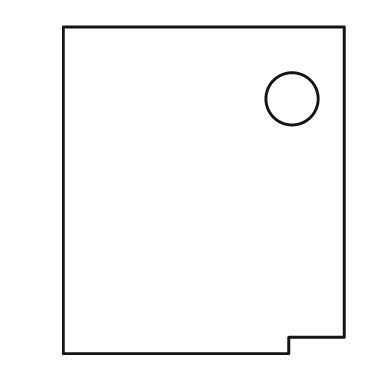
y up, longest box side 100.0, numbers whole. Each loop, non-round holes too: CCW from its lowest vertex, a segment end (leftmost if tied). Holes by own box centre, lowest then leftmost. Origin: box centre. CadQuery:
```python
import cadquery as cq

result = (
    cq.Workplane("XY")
    .moveTo(-43.0, -50.0)
    .lineTo(26.0, -50.0)
    .lineTo(26.0, -45.0)
    .lineTo(43.0, -45.0)
    .lineTo(43.0, 50.0)
    .lineTo(-43.0, 50.0)
    .close()
    .moveTo(27.0, 28.0)
    .circle(8.0)
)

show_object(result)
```